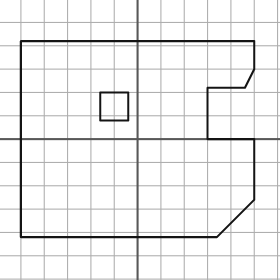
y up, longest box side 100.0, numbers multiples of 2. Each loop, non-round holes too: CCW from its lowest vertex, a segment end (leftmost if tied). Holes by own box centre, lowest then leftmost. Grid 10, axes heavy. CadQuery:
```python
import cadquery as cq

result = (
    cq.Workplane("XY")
    .moveTo(-50.0, -42.0)
    .lineTo(34.0, -42.0)
    .lineTo(50.0, -26.0)
    .lineTo(50.0, 0.0)
    .lineTo(30.0, 0.0)
    .lineTo(30.0, 22.0)
    .lineTo(46.0, 22.0)
    .lineTo(50.0, 30.0)
    .lineTo(50.0, 42.0)
    .lineTo(-50.0, 42.0)
    .close()
    .moveTo(-16.0, 8.0)
    .lineTo(-4.0, 8.0)
    .lineTo(-4.0, 20.0)
    .lineTo(-16.0, 20.0)
    .close()
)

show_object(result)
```